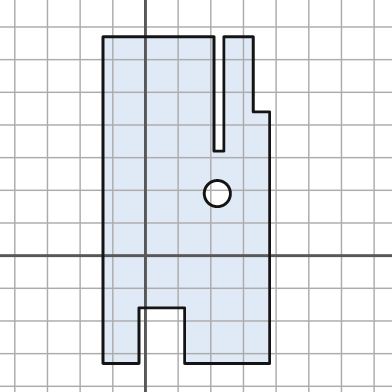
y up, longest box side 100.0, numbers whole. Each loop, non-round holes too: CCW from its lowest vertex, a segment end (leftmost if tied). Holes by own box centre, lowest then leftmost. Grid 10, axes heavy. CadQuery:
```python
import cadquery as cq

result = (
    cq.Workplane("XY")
    .moveTo(-13.0, -33.0)
    .lineTo(-2.0, -33.0)
    .lineTo(-2.0, -16.0)
    .lineTo(12.0, -16.0)
    .lineTo(12.0, -33.0)
    .lineTo(38.0, -33.0)
    .lineTo(38.0, 44.0)
    .lineTo(33.0, 44.0)
    .lineTo(33.0, 67.0)
    .lineTo(24.0, 67.0)
    .lineTo(24.0, 32.0)
    .lineTo(21.0, 32.0)
    .lineTo(21.0, 67.0)
    .lineTo(-13.0, 67.0)
    .close()
    .moveTo(22.0, 19.0)
    .circle(4.0)
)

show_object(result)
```